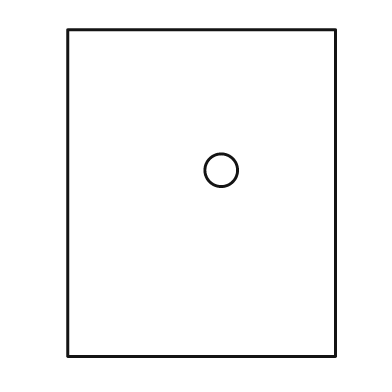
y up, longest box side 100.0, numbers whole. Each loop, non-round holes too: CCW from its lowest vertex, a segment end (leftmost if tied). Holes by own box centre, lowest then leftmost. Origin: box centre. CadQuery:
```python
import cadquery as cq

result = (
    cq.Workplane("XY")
    .moveTo(-41.0, -50.0)
    .lineTo(41.0, -50.0)
    .lineTo(41.0, 50.0)
    .lineTo(-41.0, 50.0)
    .close()
    .moveTo(6.0, 7.0)
    .circle(5.0)
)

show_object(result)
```